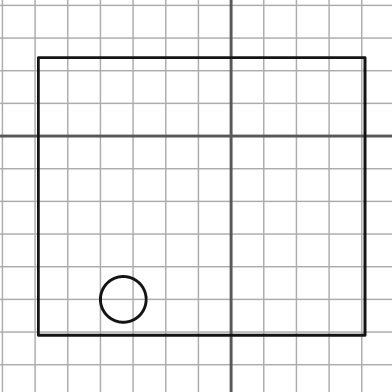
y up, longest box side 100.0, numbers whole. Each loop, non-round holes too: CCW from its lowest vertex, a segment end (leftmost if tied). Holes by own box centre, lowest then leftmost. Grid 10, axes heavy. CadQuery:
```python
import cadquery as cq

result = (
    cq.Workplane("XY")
    .moveTo(-59.0, -61.0)
    .lineTo(41.0, -61.0)
    .lineTo(41.0, 24.0)
    .lineTo(-59.0, 24.0)
    .close()
    .moveTo(-33.0, -50.0)
    .circle(7.0)
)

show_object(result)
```